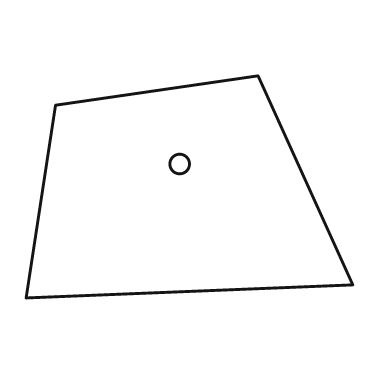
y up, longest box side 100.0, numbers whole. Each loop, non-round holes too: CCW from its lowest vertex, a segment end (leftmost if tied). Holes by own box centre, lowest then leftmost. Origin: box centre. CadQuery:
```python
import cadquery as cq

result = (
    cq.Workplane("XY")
    .moveTo(-50.0, -34.0)
    .lineTo(50.0, -30.0)
    .lineTo(21.0, 34.0)
    .lineTo(-41.0, 25.0)
    .close()
    .moveTo(-3.0, 7.0)
    .circle(3.0)
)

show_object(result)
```